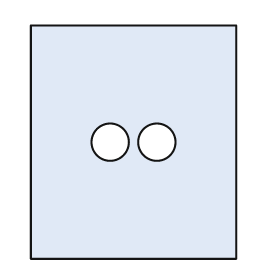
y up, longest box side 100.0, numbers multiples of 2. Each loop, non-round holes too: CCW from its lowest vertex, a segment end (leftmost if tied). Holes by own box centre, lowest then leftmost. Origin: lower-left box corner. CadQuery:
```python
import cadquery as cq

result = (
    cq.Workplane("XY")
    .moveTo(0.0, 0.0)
    .lineTo(88.0, 0.0)
    .lineTo(88.0, 100.0)
    .lineTo(0.0, 100.0)
    .close()
    .moveTo(34.0, 50.0)
    .circle(8.0)
    .moveTo(54.0, 50.0)
    .circle(8.0)
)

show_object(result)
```